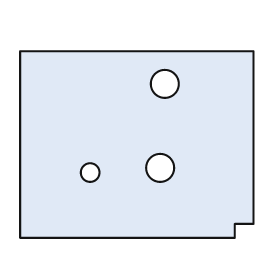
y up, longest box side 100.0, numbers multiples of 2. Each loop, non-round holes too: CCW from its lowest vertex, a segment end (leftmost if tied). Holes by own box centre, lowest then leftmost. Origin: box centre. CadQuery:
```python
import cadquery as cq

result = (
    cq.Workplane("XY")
    .moveTo(-50.0, -40.0)
    .lineTo(42.0, -40.0)
    .lineTo(42.0, -34.0)
    .lineTo(50.0, -34.0)
    .lineTo(50.0, 40.0)
    .lineTo(-50.0, 40.0)
    .close()
    .moveTo(-20.0, -12.0)
    .circle(4.0)
    .moveTo(10.0, -10.0)
    .circle(6.0)
    .moveTo(12.0, 26.0)
    .circle(6.0)
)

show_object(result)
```